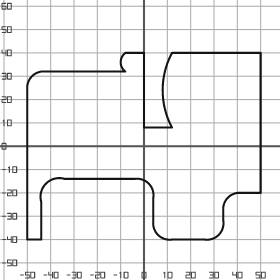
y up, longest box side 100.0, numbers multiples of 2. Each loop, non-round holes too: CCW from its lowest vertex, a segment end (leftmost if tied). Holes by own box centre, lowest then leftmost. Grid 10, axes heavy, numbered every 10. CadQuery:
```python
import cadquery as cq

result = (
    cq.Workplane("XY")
    .moveTo(-50.0, -40.0)
    .lineTo(-44.0, -40.0)
    .lineTo(-44.0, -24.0)
    .threePointArc((-42.0, -16.0), (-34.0, -14.0))
    .lineTo(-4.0, -14.0)
    .threePointArc((2.0, -16.0), (4.0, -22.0))
    .lineTo(4.0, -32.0)
    .threePointArc((6.0, -38.0), (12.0, -40.0))
    .lineTo(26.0, -40.0)
    .threePointArc((32.0, -38.0), (34.0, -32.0))
    .lineTo(34.0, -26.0)
    .threePointArc((36.0, -22.0), (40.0, -20.0))
    .lineTo(50.0, -20.0)
    .lineTo(50.0, 40.0)
    .lineTo(12.0, 40.0)
    .threePointArc((8.0, 24.0), (12.0, 8.0))
    .lineTo(0.0, 8.0)
    .lineTo(0.0, 40.0)
    .lineTo(-8.0, 40.0)
    .threePointArc((-10.0, 36.0), (-8.0, 32.0))
    .lineTo(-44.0, 32.0)
    .threePointArc((-48.0, 30.0), (-50.0, 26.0))
    .close()
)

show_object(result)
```